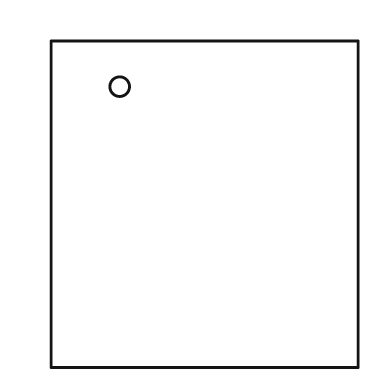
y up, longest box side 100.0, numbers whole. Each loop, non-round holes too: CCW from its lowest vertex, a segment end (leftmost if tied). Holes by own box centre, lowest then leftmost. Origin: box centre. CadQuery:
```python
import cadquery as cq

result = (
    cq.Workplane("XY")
    .moveTo(-47.0, -50.0)
    .lineTo(47.0, -50.0)
    .lineTo(47.0, 50.0)
    .lineTo(-47.0, 50.0)
    .close()
    .moveTo(-26.0, 36.0)
    .circle(3.0)
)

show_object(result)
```